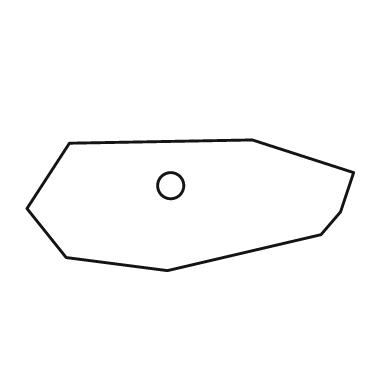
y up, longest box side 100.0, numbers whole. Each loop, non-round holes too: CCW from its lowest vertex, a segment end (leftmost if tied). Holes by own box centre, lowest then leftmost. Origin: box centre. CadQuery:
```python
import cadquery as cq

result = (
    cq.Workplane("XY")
    .moveTo(-7.0, -20.0)
    .lineTo(40.0, -9.0)
    .lineTo(46.0, -2.0)
    .lineTo(50.0, 10.0)
    .lineTo(19.0, 20.0)
    .lineTo(-37.0, 19.0)
    .lineTo(-50.0, -1.0)
    .lineTo(-38.0, -16.0)
    .close()
    .moveTo(-6.0, 6.0)
    .circle(4.0)
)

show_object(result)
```